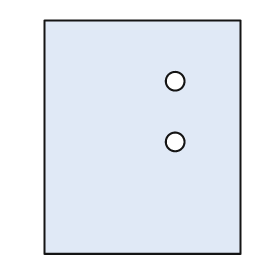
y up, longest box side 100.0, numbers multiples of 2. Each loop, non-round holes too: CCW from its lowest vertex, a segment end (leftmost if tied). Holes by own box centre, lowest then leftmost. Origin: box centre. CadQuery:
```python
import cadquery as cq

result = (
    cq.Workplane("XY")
    .moveTo(-42.0, -50.0)
    .lineTo(42.0, -50.0)
    .lineTo(42.0, 50.0)
    .lineTo(-42.0, 50.0)
    .close()
    .moveTo(14.0, -2.0)
    .circle(4.0)
    .moveTo(14.0, 24.0)
    .circle(4.0)
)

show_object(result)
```